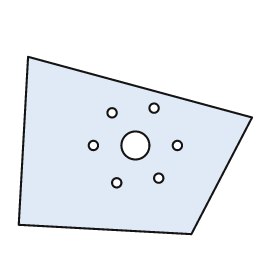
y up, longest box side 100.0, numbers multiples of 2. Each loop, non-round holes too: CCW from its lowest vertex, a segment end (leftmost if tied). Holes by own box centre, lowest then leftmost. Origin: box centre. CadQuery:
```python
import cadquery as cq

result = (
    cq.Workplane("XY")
    .moveTo(24.0, -38.0)
    .lineTo(50.0, 12.0)
    .lineTo(-46.0, 38.0)
    .lineTo(-50.0, -34.0)
    .close()
    .moveTo(-8.0, -16.0)
    .circle(2.0)
    .moveTo(10.0, -14.0)
    .circle(2.0)
    .moveTo(-18.0, 0.0)
    .circle(2.0)
    .moveTo(0.0, 0.0)
    .circle(6.0)
    .moveTo(18.0, 0.0)
    .circle(2.0)
    .moveTo(-10.0, 14.0)
    .circle(2.0)
    .moveTo(8.0, 16.0)
    .circle(2.0)
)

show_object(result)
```